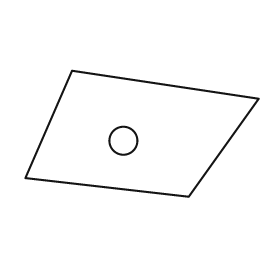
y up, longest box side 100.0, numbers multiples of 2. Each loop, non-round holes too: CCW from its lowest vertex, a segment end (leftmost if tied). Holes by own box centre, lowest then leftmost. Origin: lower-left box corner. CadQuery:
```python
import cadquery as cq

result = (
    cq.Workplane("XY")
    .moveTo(70.0, 0.0)
    .lineTo(100.0, 42.0)
    .lineTo(20.0, 54.0)
    .lineTo(0.0, 8.0)
    .close()
    .moveTo(42.0, 24.0)
    .circle(6.0)
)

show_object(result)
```